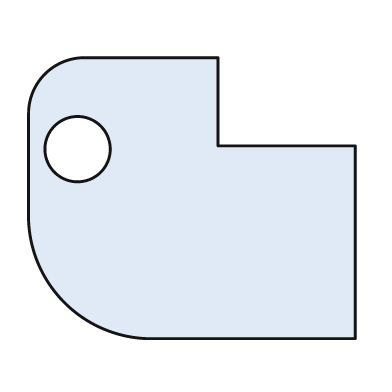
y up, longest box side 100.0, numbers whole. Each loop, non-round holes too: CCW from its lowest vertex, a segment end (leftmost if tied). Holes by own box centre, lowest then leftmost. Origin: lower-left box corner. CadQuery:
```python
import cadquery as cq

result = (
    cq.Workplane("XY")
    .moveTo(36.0, 0.0)
    .lineTo(100.0, 0.0)
    .lineTo(100.0, 59.0)
    .lineTo(58.0, 59.0)
    .lineTo(58.0, 86.0)
    .lineTo(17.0, 86.0)
    .threePointArc((5.0, 81.0), (0.0, 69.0))
    .lineTo(0.0, 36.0)
    .threePointArc((11.0, 11.0), (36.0, 0.0))
    .close()
    .moveTo(15.0, 58.0)
    .circle(10.0)
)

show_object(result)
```